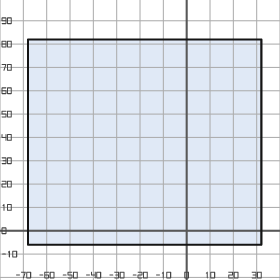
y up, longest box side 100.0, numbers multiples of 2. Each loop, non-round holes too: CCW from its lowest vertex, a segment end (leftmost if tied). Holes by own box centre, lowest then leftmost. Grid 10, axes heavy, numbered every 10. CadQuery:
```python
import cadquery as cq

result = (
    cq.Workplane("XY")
    .moveTo(-68.0, -6.0)
    .lineTo(32.0, -6.0)
    .lineTo(32.0, 82.0)
    .lineTo(-68.0, 82.0)
    .close()
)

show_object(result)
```